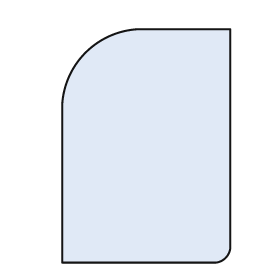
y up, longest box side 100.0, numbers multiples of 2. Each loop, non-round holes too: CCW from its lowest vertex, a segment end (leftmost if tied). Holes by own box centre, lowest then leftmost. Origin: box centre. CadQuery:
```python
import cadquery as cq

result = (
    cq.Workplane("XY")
    .moveTo(-36.0, -50.0)
    .lineTo(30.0, -50.0)
    .threePointArc((34.0, -48.0), (36.0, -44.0))
    .lineTo(36.0, 50.0)
    .lineTo(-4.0, 50.0)
    .threePointArc((-26.0, 40.0), (-36.0, 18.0))
    .close()
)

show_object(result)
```